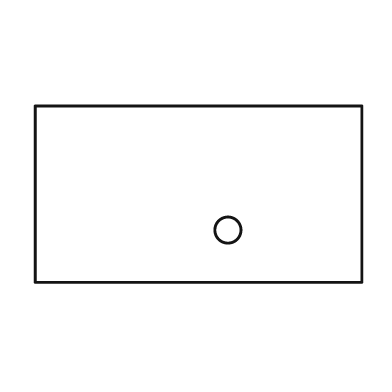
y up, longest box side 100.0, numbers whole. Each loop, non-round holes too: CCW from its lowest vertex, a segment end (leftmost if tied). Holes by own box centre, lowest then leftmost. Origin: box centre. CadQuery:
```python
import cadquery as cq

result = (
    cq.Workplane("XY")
    .moveTo(-50.0, -27.0)
    .lineTo(50.0, -27.0)
    .lineTo(50.0, 27.0)
    .lineTo(-50.0, 27.0)
    .close()
    .moveTo(9.0, -11.0)
    .circle(4.0)
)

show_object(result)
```